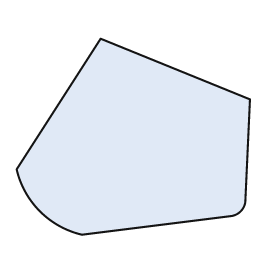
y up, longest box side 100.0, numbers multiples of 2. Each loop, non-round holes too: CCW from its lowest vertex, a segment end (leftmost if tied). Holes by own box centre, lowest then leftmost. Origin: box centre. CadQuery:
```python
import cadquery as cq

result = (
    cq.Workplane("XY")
    .moveTo(-22.0, -42.0)
    .lineTo(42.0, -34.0)
    .threePointArc((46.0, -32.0), (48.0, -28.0))
    .lineTo(50.0, 16.0)
    .lineTo(-14.0, 42.0)
    .lineTo(-50.0, -14.0)
    .threePointArc((-40.0, -32.0), (-22.0, -42.0))
    .close()
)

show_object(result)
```